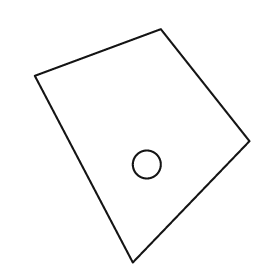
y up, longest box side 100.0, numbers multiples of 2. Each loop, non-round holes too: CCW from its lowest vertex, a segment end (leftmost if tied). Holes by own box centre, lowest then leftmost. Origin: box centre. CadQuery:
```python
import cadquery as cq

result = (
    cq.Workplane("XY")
    .moveTo(-4.0, -50.0)
    .lineTo(46.0, 2.0)
    .lineTo(8.0, 50.0)
    .lineTo(-46.0, 30.0)
    .close()
    .moveTo(2.0, -8.0)
    .circle(6.0)
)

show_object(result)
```